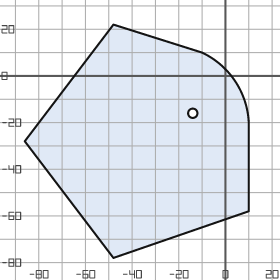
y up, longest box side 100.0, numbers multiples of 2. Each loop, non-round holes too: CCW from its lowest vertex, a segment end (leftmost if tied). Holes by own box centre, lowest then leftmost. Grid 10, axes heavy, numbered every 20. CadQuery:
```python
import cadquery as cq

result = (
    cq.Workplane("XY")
    .moveTo(-48.0, -78.0)
    .lineTo(10.0, -58.0)
    .lineTo(10.0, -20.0)
    .threePointArc((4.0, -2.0), (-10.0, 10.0))
    .lineTo(-48.0, 22.0)
    .lineTo(-86.0, -28.0)
    .close()
    .moveTo(-14.0, -16.0)
    .circle(2.0)
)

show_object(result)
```